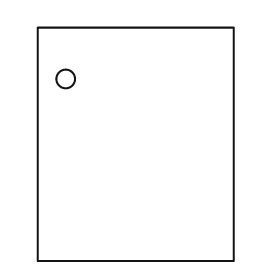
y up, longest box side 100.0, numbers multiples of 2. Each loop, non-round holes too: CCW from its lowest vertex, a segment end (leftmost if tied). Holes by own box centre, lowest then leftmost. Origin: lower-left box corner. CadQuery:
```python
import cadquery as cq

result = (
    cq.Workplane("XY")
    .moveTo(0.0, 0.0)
    .lineTo(84.0, 0.0)
    .lineTo(84.0, 100.0)
    .lineTo(0.0, 100.0)
    .close()
    .moveTo(12.0, 78.0)
    .circle(4.0)
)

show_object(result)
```